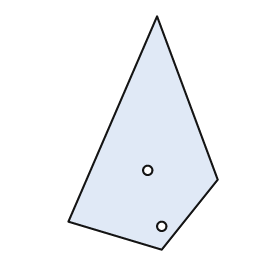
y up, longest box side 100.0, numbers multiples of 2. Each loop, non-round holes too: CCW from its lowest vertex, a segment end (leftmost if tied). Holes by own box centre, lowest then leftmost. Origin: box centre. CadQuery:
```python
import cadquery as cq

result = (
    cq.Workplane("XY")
    .moveTo(8.0, -50.0)
    .lineTo(32.0, -20.0)
    .lineTo(6.0, 50.0)
    .lineTo(-32.0, -38.0)
    .close()
    .moveTo(8.0, -40.0)
    .circle(2.0)
    .moveTo(2.0, -16.0)
    .circle(2.0)
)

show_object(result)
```